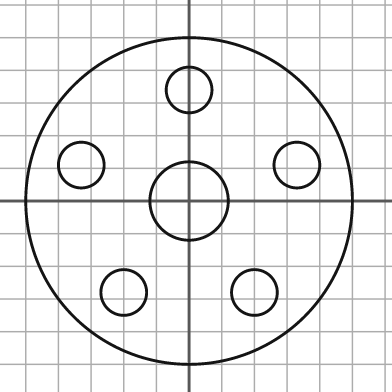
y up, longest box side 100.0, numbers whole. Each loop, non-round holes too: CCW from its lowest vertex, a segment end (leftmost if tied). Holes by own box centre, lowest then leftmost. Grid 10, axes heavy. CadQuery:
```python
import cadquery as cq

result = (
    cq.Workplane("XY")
    .moveTo(0.0, 0.0)
    .circle(50.0)
    .moveTo(-20.0, -28.0)
    .circle(7.0)
    .moveTo(20.0, -28.0)
    .circle(7.0)
    .moveTo(0.0, 0.0)
    .circle(12.0)
    .moveTo(-33.0, 11.0)
    .circle(7.0)
    .moveTo(33.0, 11.0)
    .circle(7.0)
    .moveTo(0.0, 34.0)
    .circle(7.0)
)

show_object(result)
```